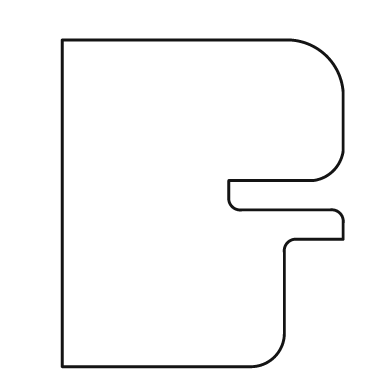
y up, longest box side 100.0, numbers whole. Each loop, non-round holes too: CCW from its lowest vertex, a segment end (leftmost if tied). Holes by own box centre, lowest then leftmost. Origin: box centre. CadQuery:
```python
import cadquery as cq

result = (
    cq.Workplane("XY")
    .moveTo(-43.0, -50.0)
    .lineTo(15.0, -50.0)
    .threePointArc((22.0, -47.0), (25.0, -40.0))
    .lineTo(25.0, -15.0)
    .threePointArc((26.0, -12.0), (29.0, -11.0))
    .lineTo(43.0, -11.0)
    .lineTo(43.0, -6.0)
    .threePointArc((42.0, -3.0), (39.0, -2.0))
    .lineTo(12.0, -2.0)
    .threePointArc((9.0, -1.0), (8.0, 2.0))
    .lineTo(8.0, 7.0)
    .lineTo(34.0, 7.0)
    .threePointArc((40.0, 10.0), (43.0, 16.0))
    .lineTo(43.0, 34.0)
    .threePointArc((38.0, 45.0), (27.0, 50.0))
    .lineTo(-43.0, 50.0)
    .close()
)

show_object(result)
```